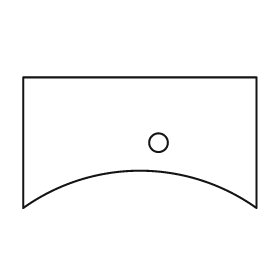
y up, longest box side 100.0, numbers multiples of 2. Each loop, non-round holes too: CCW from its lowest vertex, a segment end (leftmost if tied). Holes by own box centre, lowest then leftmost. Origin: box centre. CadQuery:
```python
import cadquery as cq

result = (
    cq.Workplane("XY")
    .moveTo(-50.0, -28.0)
    .threePointArc((0.0, -12.0), (50.0, -28.0))
    .lineTo(50.0, 28.0)
    .lineTo(-50.0, 28.0)
    .close()
    .moveTo(8.0, 0.0)
    .circle(4.0)
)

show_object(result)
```